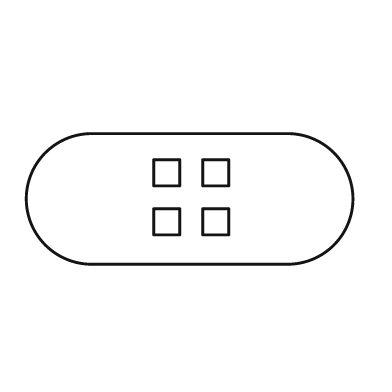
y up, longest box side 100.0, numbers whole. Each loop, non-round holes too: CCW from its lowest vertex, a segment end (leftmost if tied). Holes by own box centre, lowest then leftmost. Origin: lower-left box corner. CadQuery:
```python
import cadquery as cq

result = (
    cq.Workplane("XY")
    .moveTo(20.0, 0.0)
    .lineTo(80.0, 0.0)
    .threePointArc((100.0, 20.0), (80.0, 40.0))
    .lineTo(20.0, 40.0)
    .threePointArc((0.0, 20.0), (20.0, 0.0))
    .close()
    .moveTo(39.0, 9.0)
    .lineTo(47.0, 9.0)
    .lineTo(47.0, 17.0)
    .lineTo(39.0, 17.0)
    .close()
    .moveTo(54.0, 9.0)
    .lineTo(62.0, 9.0)
    .lineTo(62.0, 17.0)
    .lineTo(54.0, 17.0)
    .close()
    .moveTo(39.0, 24.0)
    .lineTo(47.0, 24.0)
    .lineTo(47.0, 32.0)
    .lineTo(39.0, 32.0)
    .close()
    .moveTo(54.0, 24.0)
    .lineTo(62.0, 24.0)
    .lineTo(62.0, 32.0)
    .lineTo(54.0, 32.0)
    .close()
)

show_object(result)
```